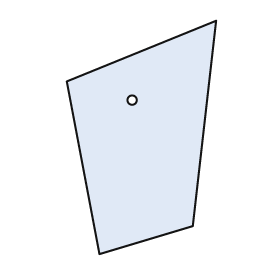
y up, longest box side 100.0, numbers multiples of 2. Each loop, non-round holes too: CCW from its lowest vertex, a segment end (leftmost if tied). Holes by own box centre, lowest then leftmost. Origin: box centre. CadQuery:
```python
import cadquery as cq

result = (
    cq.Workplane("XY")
    .moveTo(-18.0, -50.0)
    .lineTo(22.0, -38.0)
    .lineTo(32.0, 50.0)
    .lineTo(-32.0, 24.0)
    .close()
    .moveTo(-4.0, 16.0)
    .circle(2.0)
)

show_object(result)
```